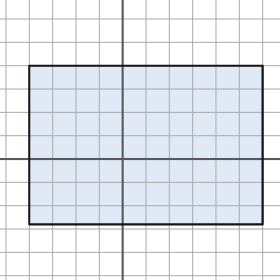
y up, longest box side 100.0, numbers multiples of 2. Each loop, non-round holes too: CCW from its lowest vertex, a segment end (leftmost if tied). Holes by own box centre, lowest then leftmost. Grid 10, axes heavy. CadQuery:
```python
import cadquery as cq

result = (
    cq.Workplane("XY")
    .moveTo(-40.0, -28.0)
    .lineTo(60.0, -28.0)
    .lineTo(60.0, 40.0)
    .lineTo(-40.0, 40.0)
    .close()
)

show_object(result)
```